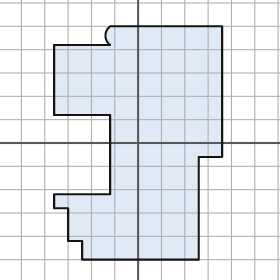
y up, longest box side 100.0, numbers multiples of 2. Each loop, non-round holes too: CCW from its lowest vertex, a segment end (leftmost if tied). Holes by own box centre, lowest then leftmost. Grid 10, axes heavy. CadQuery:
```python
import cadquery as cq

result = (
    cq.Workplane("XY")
    .moveTo(-24.0, -50.0)
    .lineTo(26.0, -50.0)
    .lineTo(26.0, -6.0)
    .lineTo(36.0, -6.0)
    .lineTo(36.0, 50.0)
    .lineTo(-12.0, 50.0)
    .threePointArc((-14.0, 46.0), (-12.0, 42.0))
    .lineTo(-36.0, 42.0)
    .lineTo(-36.0, 12.0)
    .lineTo(-12.0, 12.0)
    .lineTo(-12.0, -22.0)
    .lineTo(-36.0, -22.0)
    .lineTo(-36.0, -28.0)
    .lineTo(-30.0, -28.0)
    .lineTo(-30.0, -42.0)
    .lineTo(-24.0, -42.0)
    .close()
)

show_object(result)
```